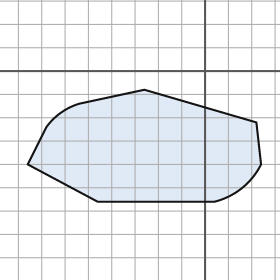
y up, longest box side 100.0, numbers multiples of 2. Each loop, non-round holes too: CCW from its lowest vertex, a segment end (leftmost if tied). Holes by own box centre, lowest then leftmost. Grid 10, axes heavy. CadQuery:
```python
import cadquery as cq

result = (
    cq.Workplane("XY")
    .moveTo(-46.0, -56.0)
    .lineTo(4.0, -56.0)
    .threePointArc((16.0, -50.0), (24.0, -40.0))
    .lineTo(22.0, -22.0)
    .lineTo(-26.0, -8.0)
    .lineTo(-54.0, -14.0)
    .threePointArc((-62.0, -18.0), (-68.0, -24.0))
    .lineTo(-76.0, -40.0)
    .close()
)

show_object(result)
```